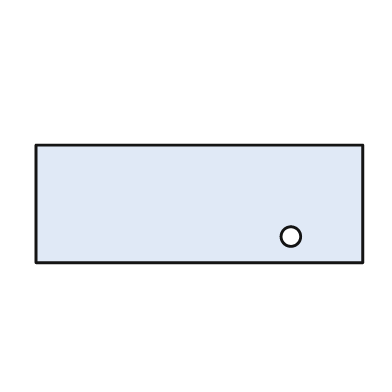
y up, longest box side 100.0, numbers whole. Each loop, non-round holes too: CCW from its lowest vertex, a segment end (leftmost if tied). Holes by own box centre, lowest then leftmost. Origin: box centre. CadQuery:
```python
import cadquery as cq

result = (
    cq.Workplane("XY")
    .moveTo(-50.0, -18.0)
    .lineTo(50.0, -18.0)
    .lineTo(50.0, 18.0)
    .lineTo(-50.0, 18.0)
    .close()
    .moveTo(28.0, -10.0)
    .circle(3.0)
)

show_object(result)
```